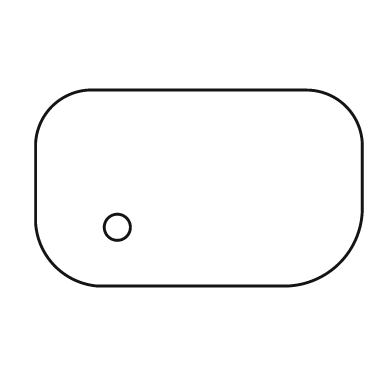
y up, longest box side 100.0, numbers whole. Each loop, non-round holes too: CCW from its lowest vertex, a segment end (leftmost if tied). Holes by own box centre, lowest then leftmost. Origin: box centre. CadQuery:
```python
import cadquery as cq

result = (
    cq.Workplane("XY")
    .moveTo(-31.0, -30.0)
    .lineTo(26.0, -30.0)
    .threePointArc((43.0, -23.0), (50.0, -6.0))
    .lineTo(50.0, 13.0)
    .threePointArc((45.0, 25.0), (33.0, 30.0))
    .lineTo(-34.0, 30.0)
    .threePointArc((-45.0, 25.0), (-50.0, 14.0))
    .lineTo(-50.0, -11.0)
    .threePointArc((-44.0, -24.0), (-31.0, -30.0))
    .close()
    .moveTo(-25.0, -12.0)
    .circle(4.0)
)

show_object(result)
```